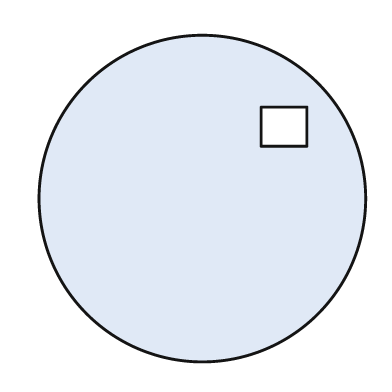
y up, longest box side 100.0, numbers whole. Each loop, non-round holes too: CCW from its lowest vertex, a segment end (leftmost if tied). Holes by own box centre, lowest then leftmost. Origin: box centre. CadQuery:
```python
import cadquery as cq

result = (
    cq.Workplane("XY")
    .moveTo(0.0, 0.0)
    .circle(50.0)
    .moveTo(18.0, 16.0)
    .lineTo(32.0, 16.0)
    .lineTo(32.0, 28.0)
    .lineTo(18.0, 28.0)
    .close()
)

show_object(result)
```